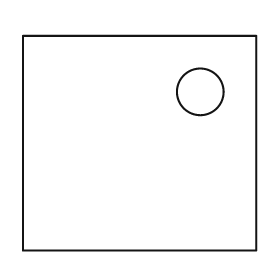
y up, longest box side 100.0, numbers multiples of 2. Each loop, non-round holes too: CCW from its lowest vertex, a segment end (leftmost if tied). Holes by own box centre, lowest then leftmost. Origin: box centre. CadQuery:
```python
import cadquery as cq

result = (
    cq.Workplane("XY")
    .moveTo(-50.0, -46.0)
    .lineTo(50.0, -46.0)
    .lineTo(50.0, 46.0)
    .lineTo(-50.0, 46.0)
    .close()
    .moveTo(26.0, 22.0)
    .circle(10.0)
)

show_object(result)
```